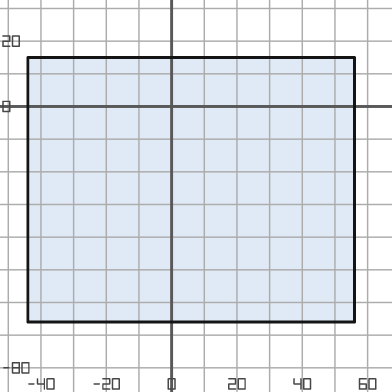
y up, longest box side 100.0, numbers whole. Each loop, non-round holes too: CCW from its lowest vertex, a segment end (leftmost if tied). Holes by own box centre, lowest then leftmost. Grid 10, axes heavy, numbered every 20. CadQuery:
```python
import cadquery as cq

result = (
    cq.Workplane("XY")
    .moveTo(-44.0, -66.0)
    .lineTo(56.0, -66.0)
    .lineTo(56.0, 15.0)
    .lineTo(-44.0, 15.0)
    .close()
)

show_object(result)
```